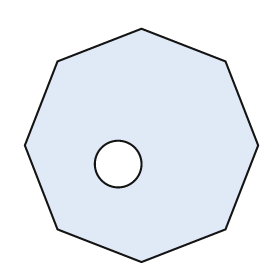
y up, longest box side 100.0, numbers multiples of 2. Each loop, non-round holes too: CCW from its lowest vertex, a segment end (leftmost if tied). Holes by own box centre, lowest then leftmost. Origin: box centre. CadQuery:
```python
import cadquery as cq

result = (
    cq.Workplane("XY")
    .moveTo(0.0, -50.0)
    .lineTo(36.0, -36.0)
    .lineTo(50.0, 0.0)
    .lineTo(36.0, 36.0)
    .lineTo(0.0, 50.0)
    .lineTo(-36.0, 36.0)
    .lineTo(-50.0, 0.0)
    .lineTo(-36.0, -36.0)
    .close()
    .moveTo(-10.0, -8.0)
    .circle(10.0)
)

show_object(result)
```